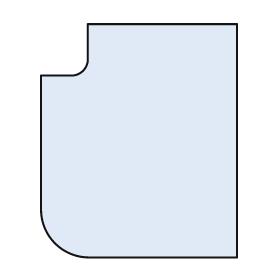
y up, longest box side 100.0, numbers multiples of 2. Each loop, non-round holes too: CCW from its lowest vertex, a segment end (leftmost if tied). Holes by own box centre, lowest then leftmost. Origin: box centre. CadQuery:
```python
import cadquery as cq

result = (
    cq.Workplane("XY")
    .moveTo(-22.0, -50.0)
    .lineTo(42.0, -50.0)
    .lineTo(42.0, 50.0)
    .lineTo(-22.0, 50.0)
    .lineTo(-22.0, 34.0)
    .threePointArc((-24.0, 30.0), (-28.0, 28.0))
    .lineTo(-42.0, 28.0)
    .lineTo(-42.0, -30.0)
    .threePointArc((-36.0, -44.0), (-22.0, -50.0))
    .close()
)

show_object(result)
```